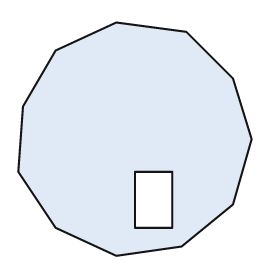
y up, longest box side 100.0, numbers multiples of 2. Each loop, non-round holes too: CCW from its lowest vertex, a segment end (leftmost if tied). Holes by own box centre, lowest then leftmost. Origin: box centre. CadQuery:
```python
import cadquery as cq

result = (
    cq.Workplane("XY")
    .moveTo(-8.0, -50.0)
    .lineTo(20.0, -46.0)
    .lineTo(42.0, -28.0)
    .lineTo(50.0, 0.0)
    .lineTo(42.0, 26.0)
    .lineTo(22.0, 46.0)
    .lineTo(-8.0, 50.0)
    .lineTo(-34.0, 38.0)
    .lineTo(-48.0, 14.0)
    .lineTo(-50.0, -14.0)
    .lineTo(-34.0, -38.0)
    .close()
    .moveTo(0.0, -38.0)
    .lineTo(16.0, -38.0)
    .lineTo(16.0, -14.0)
    .lineTo(0.0, -14.0)
    .close()
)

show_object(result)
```